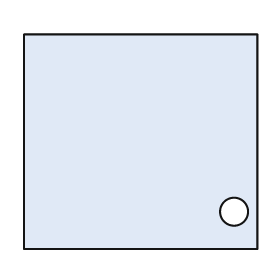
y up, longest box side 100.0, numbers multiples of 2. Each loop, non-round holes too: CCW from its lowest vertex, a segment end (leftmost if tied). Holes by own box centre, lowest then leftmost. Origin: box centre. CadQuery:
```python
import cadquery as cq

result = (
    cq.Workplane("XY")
    .moveTo(-50.0, -46.0)
    .lineTo(50.0, -46.0)
    .lineTo(50.0, 46.0)
    .lineTo(-50.0, 46.0)
    .close()
    .moveTo(40.0, -30.0)
    .circle(6.0)
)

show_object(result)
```